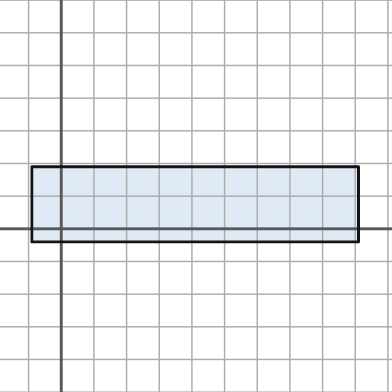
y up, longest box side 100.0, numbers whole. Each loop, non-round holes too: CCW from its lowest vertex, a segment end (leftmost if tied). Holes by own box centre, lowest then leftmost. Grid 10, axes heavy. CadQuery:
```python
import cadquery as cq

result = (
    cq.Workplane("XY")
    .moveTo(-9.0, -4.0)
    .lineTo(91.0, -4.0)
    .lineTo(91.0, 19.0)
    .lineTo(-9.0, 19.0)
    .close()
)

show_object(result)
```